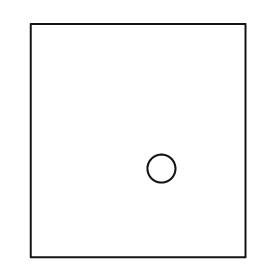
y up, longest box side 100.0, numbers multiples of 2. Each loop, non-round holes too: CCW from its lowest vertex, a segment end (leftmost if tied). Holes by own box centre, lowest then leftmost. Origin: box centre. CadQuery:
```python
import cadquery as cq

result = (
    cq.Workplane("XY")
    .moveTo(-46.0, -50.0)
    .lineTo(46.0, -50.0)
    .lineTo(46.0, 50.0)
    .lineTo(-46.0, 50.0)
    .close()
    .moveTo(10.0, -12.0)
    .circle(6.0)
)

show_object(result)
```